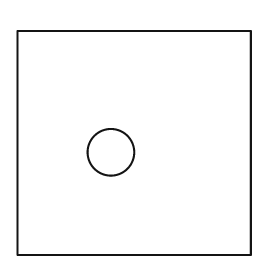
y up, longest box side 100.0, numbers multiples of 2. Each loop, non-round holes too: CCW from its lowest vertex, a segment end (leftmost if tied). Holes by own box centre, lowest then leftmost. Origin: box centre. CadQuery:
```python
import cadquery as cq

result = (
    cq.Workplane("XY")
    .moveTo(-50.0, -48.0)
    .lineTo(50.0, -48.0)
    .lineTo(50.0, 48.0)
    .lineTo(-50.0, 48.0)
    .close()
    .moveTo(-10.0, -4.0)
    .circle(10.0)
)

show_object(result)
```